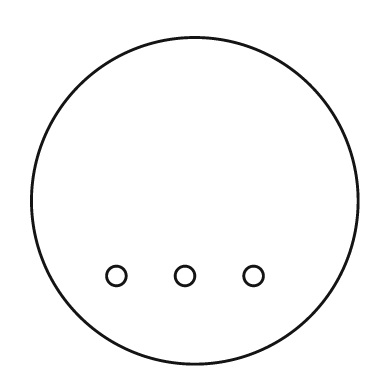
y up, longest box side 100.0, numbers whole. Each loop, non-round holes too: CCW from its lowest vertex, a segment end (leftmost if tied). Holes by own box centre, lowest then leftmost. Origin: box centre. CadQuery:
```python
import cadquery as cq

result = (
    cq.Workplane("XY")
    .moveTo(0.0, 0.0)
    .circle(50.0)
    .moveTo(-24.0, -23.0)
    .circle(3.0)
    .moveTo(-3.0, -23.0)
    .circle(3.0)
    .moveTo(18.0, -23.0)
    .circle(3.0)
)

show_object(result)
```